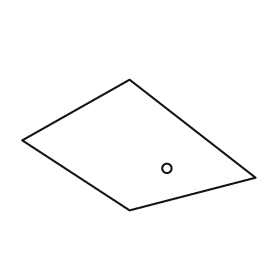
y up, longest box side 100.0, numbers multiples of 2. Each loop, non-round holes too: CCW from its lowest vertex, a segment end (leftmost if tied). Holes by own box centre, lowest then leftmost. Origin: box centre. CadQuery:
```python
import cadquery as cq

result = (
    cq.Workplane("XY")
    .moveTo(-4.0, -28.0)
    .lineTo(50.0, -14.0)
    .lineTo(-4.0, 28.0)
    .lineTo(-50.0, 2.0)
    .close()
    .moveTo(12.0, -10.0)
    .circle(2.0)
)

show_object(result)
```